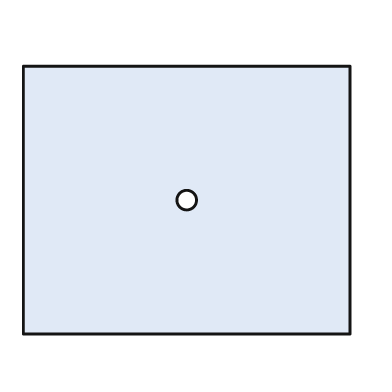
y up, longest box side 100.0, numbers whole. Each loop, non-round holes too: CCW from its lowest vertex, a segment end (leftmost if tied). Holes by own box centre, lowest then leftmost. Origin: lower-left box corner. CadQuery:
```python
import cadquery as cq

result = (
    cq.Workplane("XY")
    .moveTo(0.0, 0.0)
    .lineTo(100.0, 0.0)
    .lineTo(100.0, 82.0)
    .lineTo(0.0, 82.0)
    .close()
    .moveTo(50.0, 41.0)
    .circle(3.0)
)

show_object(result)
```